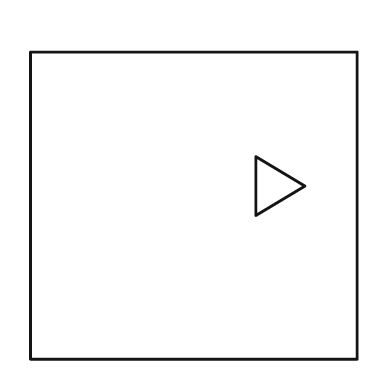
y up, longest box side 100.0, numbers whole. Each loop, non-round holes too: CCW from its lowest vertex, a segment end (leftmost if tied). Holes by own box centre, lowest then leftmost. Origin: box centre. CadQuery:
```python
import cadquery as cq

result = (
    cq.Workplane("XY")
    .moveTo(-50.0, -47.0)
    .lineTo(50.0, -47.0)
    .lineTo(50.0, 47.0)
    .lineTo(-50.0, 47.0)
    .close()
    .moveTo(19.0, -3.0)
    .lineTo(34.0, 6.0)
    .lineTo(19.0, 15.0)
    .close()
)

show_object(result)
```